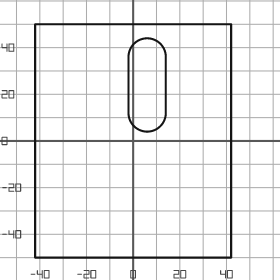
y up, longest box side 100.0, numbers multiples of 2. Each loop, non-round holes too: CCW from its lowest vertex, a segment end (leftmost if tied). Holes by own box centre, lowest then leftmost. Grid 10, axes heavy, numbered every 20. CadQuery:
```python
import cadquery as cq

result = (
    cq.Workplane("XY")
    .moveTo(-42.0, -50.0)
    .lineTo(42.0, -50.0)
    .lineTo(42.0, 50.0)
    .lineTo(-42.0, 50.0)
    .close()
    .moveTo(-2.0, 12.0)
    .threePointArc((6.0, 4.0), (14.0, 12.0))
    .lineTo(14.0, 36.0)
    .threePointArc((6.0, 44.0), (-2.0, 36.0))
    .close()
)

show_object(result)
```